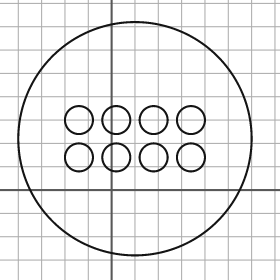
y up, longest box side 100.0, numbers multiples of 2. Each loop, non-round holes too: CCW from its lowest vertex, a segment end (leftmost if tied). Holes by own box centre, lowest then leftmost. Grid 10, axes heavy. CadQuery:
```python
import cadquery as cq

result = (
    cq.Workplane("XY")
    .moveTo(10.0, 22.0)
    .circle(50.0)
    .moveTo(-14.0, 14.0)
    .circle(6.0)
    .moveTo(2.0, 14.0)
    .circle(6.0)
    .moveTo(18.0, 14.0)
    .circle(6.0)
    .moveTo(34.0, 14.0)
    .circle(6.0)
    .moveTo(-14.0, 30.0)
    .circle(6.0)
    .moveTo(2.0, 30.0)
    .circle(6.0)
    .moveTo(18.0, 30.0)
    .circle(6.0)
    .moveTo(34.0, 30.0)
    .circle(6.0)
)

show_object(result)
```